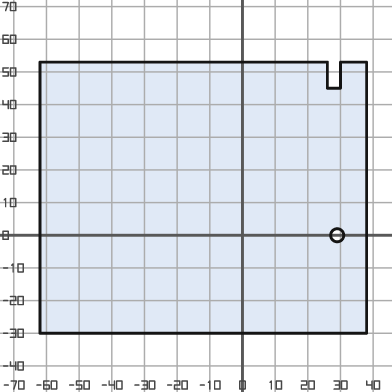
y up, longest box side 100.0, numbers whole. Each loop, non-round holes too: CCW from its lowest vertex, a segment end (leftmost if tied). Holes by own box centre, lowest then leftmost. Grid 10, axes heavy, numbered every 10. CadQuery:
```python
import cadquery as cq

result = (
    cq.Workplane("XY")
    .moveTo(-62.0, -30.0)
    .lineTo(38.0, -30.0)
    .lineTo(38.0, 53.0)
    .lineTo(30.0, 53.0)
    .lineTo(30.0, 45.0)
    .lineTo(26.0, 45.0)
    .lineTo(26.0, 53.0)
    .lineTo(-62.0, 53.0)
    .close()
    .moveTo(29.0, 0.0)
    .circle(2.0)
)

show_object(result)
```